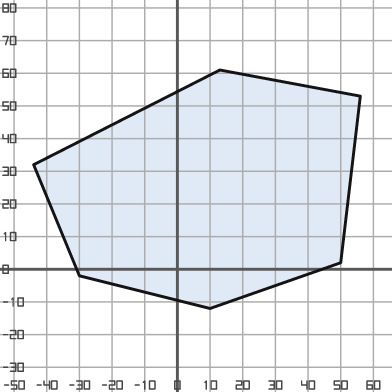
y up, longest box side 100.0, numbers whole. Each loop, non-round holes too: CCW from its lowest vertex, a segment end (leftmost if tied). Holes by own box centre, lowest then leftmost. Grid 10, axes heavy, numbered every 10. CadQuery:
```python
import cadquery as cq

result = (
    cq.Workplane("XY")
    .moveTo(10.0, -12.0)
    .lineTo(50.0, 2.0)
    .lineTo(56.0, 53.0)
    .lineTo(13.0, 61.0)
    .lineTo(-44.0, 32.0)
    .lineTo(-30.0, -2.0)
    .close()
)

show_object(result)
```